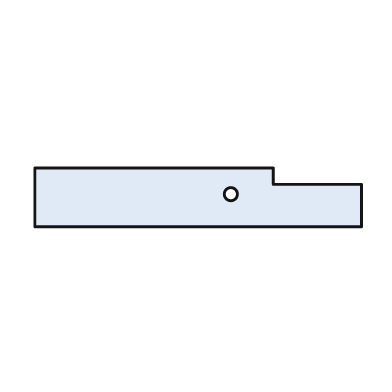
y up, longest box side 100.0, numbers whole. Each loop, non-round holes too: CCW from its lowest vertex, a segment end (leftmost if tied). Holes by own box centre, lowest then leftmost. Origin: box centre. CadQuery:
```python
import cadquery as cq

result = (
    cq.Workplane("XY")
    .moveTo(-50.0, -9.0)
    .lineTo(50.0, -9.0)
    .lineTo(50.0, 4.0)
    .lineTo(23.0, 4.0)
    .lineTo(23.0, 9.0)
    .lineTo(-50.0, 9.0)
    .close()
    .moveTo(10.0, 1.0)
    .circle(2.0)
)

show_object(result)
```